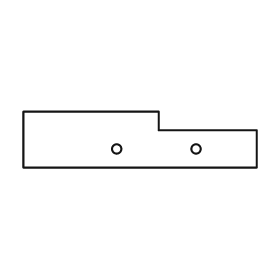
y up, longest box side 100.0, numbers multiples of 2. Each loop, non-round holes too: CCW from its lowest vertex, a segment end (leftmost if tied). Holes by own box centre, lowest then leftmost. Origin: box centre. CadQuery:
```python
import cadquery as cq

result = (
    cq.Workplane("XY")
    .moveTo(-50.0, -12.0)
    .lineTo(50.0, -12.0)
    .lineTo(50.0, 4.0)
    .lineTo(8.0, 4.0)
    .lineTo(8.0, 12.0)
    .lineTo(-50.0, 12.0)
    .close()
    .moveTo(-10.0, -4.0)
    .circle(2.0)
    .moveTo(24.0, -4.0)
    .circle(2.0)
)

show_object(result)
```